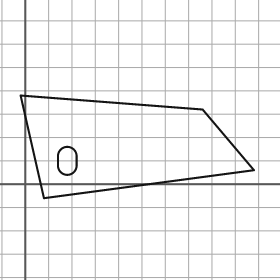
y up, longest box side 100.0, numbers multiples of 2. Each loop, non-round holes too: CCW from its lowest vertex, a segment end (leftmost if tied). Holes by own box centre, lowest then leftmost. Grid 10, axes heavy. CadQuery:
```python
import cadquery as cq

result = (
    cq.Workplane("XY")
    .moveTo(8.0, -6.0)
    .lineTo(98.0, 6.0)
    .lineTo(76.0, 32.0)
    .lineTo(-2.0, 38.0)
    .close()
    .moveTo(14.0, 8.0)
    .threePointArc((18.0, 4.0), (22.0, 8.0))
    .lineTo(22.0, 12.0)
    .threePointArc((18.0, 16.0), (14.0, 12.0))
    .close()
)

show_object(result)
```